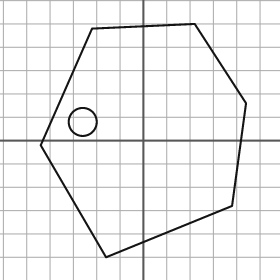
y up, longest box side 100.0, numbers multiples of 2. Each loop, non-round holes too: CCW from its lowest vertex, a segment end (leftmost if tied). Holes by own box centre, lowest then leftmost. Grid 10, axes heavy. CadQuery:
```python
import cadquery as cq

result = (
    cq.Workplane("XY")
    .moveTo(-16.0, -50.0)
    .lineTo(38.0, -28.0)
    .lineTo(44.0, 16.0)
    .lineTo(22.0, 50.0)
    .lineTo(-22.0, 48.0)
    .lineTo(-44.0, -2.0)
    .close()
    .moveTo(-26.0, 8.0)
    .circle(6.0)
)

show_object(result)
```